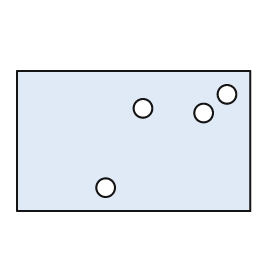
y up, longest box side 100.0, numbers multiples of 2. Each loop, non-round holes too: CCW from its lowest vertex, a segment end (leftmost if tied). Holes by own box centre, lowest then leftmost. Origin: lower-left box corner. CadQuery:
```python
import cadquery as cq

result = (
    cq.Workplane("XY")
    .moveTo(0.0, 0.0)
    .lineTo(100.0, 0.0)
    .lineTo(100.0, 60.0)
    .lineTo(0.0, 60.0)
    .close()
    .moveTo(38.0, 10.0)
    .circle(4.0)
    .moveTo(80.0, 42.0)
    .circle(4.0)
    .moveTo(54.0, 44.0)
    .circle(4.0)
    .moveTo(90.0, 50.0)
    .circle(4.0)
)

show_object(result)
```